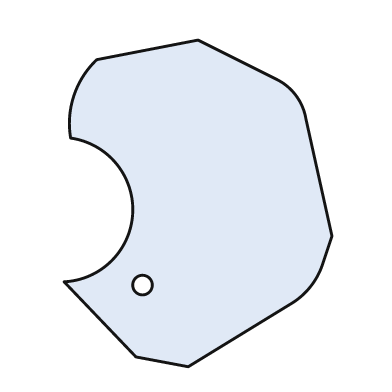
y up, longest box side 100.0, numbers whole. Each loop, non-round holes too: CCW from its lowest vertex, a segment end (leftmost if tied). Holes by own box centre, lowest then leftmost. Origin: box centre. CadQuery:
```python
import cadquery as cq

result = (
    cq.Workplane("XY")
    .moveTo(-3.0, -50.0)
    .lineTo(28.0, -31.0)
    .threePointArc((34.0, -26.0), (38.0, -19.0))
    .lineTo(41.0, -10.0)
    .lineTo(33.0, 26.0)
    .threePointArc((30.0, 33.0), (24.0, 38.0))
    .lineTo(0.0, 50.0)
    .lineTo(-31.0, 44.0)
    .threePointArc((-38.0, 33.0), (-39.0, 20.0))
    .threePointArc((-20.0, -3.0), (-41.0, -24.0))
    .lineTo(-19.0, -47.0)
    .close()
    .moveTo(-17.0, -25.0)
    .circle(3.0)
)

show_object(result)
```